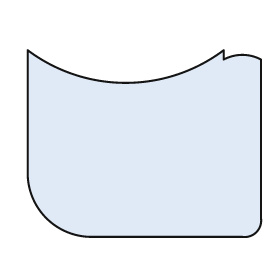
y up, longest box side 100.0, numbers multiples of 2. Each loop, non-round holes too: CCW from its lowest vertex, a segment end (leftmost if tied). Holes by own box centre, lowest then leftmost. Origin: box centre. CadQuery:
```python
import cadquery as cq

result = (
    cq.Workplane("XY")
    .moveTo(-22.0, -40.0)
    .lineTo(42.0, -40.0)
    .threePointArc((48.0, -38.0), (50.0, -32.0))
    .lineTo(50.0, 36.0)
    .threePointArc((42.0, 38.0), (34.0, 36.0))
    .lineTo(34.0, 40.0)
    .threePointArc((-8.0, 26.0), (-50.0, 40.0))
    .lineTo(-50.0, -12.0)
    .threePointArc((-42.0, -32.0), (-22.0, -40.0))
    .close()
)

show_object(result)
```